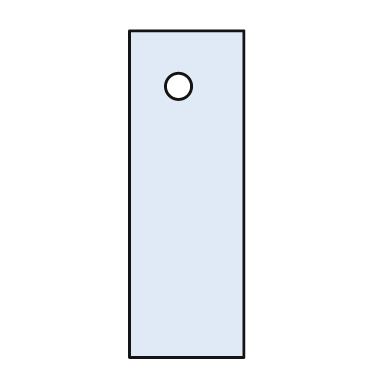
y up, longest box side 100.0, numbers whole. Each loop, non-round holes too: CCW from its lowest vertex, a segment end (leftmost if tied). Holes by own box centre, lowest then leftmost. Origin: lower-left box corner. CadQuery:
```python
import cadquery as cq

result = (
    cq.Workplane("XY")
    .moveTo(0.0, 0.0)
    .lineTo(35.0, 0.0)
    .lineTo(35.0, 100.0)
    .lineTo(0.0, 100.0)
    .close()
    .moveTo(15.0, 83.0)
    .circle(4.0)
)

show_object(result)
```